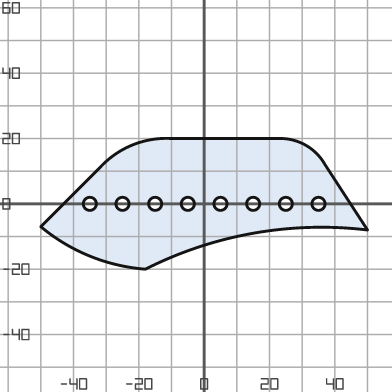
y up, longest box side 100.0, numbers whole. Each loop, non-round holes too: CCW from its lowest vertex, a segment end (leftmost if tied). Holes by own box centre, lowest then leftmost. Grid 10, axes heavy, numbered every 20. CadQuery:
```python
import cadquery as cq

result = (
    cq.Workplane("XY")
    .moveTo(-18.0, -20.0)
    .threePointArc((15.0, -9.0), (50.0, -8.0))
    .lineTo(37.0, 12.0)
    .threePointArc((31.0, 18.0), (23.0, 20.0))
    .lineTo(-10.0, 20.0)
    .threePointArc((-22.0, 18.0), (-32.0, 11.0))
    .lineTo(-50.0, -7.0)
    .threePointArc((-35.0, -16.0), (-18.0, -20.0))
    .close()
    .moveTo(-35.0, 0.0)
    .circle(2.0)
    .moveTo(-25.0, 0.0)
    .circle(2.0)
    .moveTo(-15.0, 0.0)
    .circle(2.0)
    .moveTo(-5.0, 0.0)
    .circle(2.0)
    .moveTo(5.0, 0.0)
    .circle(2.0)
    .moveTo(15.0, 0.0)
    .circle(2.0)
    .moveTo(25.0, 0.0)
    .circle(2.0)
    .moveTo(35.0, 0.0)
    .circle(2.0)
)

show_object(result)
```